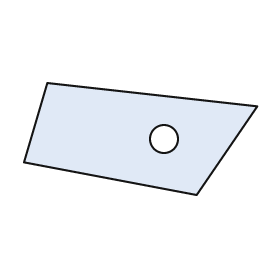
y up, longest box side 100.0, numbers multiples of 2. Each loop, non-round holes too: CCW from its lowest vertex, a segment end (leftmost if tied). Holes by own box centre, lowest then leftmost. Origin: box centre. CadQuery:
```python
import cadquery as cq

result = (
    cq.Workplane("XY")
    .moveTo(24.0, -24.0)
    .lineTo(50.0, 14.0)
    .lineTo(-40.0, 24.0)
    .lineTo(-50.0, -10.0)
    .close()
    .moveTo(10.0, 0.0)
    .circle(6.0)
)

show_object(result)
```